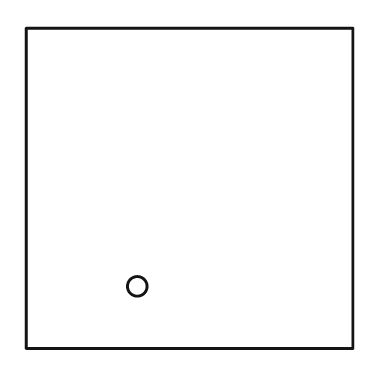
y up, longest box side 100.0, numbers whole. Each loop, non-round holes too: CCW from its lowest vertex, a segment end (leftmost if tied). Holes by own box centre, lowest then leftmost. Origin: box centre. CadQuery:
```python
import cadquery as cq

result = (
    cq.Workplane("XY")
    .moveTo(-50.0, -49.0)
    .lineTo(50.0, -49.0)
    .lineTo(50.0, 49.0)
    .lineTo(-50.0, 49.0)
    .close()
    .moveTo(-16.0, -30.0)
    .circle(3.0)
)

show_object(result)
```